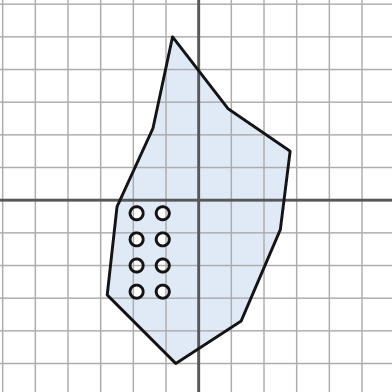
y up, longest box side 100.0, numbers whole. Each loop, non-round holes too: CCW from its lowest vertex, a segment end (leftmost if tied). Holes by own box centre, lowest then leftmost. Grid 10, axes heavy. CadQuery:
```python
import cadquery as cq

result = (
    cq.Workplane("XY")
    .moveTo(-7.0, -50.0)
    .lineTo(13.0, -37.0)
    .lineTo(25.0, -9.0)
    .lineTo(28.0, 15.0)
    .lineTo(9.0, 28.0)
    .lineTo(-8.0, 50.0)
    .lineTo(-14.0, 22.0)
    .lineTo(-25.0, -2.0)
    .lineTo(-28.0, -29.0)
    .close()
    .moveTo(-19.0, -28.0)
    .circle(2.0)
    .moveTo(-11.0, -28.0)
    .circle(2.0)
    .moveTo(-19.0, -20.0)
    .circle(2.0)
    .moveTo(-11.0, -20.0)
    .circle(2.0)
    .moveTo(-19.0, -12.0)
    .circle(2.0)
    .moveTo(-11.0, -12.0)
    .circle(2.0)
    .moveTo(-19.0, -4.0)
    .circle(2.0)
    .moveTo(-11.0, -4.0)
    .circle(2.0)
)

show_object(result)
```